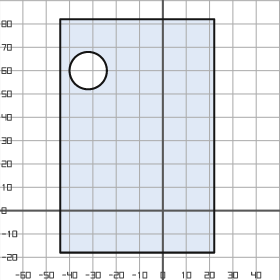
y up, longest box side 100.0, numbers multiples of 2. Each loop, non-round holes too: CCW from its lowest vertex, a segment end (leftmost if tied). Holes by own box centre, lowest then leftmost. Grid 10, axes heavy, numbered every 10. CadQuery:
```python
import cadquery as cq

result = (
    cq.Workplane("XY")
    .moveTo(-44.0, -18.0)
    .lineTo(22.0, -18.0)
    .lineTo(22.0, 82.0)
    .lineTo(-44.0, 82.0)
    .close()
    .moveTo(-32.0, 60.0)
    .circle(8.0)
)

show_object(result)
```